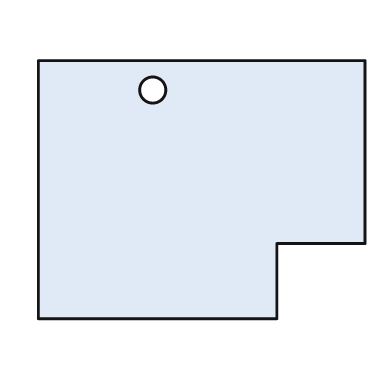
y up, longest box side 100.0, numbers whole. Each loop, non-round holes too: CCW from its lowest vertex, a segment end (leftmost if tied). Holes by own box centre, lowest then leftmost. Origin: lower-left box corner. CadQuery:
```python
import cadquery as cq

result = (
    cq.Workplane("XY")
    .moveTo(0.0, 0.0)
    .lineTo(73.0, 0.0)
    .lineTo(73.0, 23.0)
    .lineTo(100.0, 23.0)
    .lineTo(100.0, 79.0)
    .lineTo(0.0, 79.0)
    .close()
    .moveTo(35.0, 70.0)
    .circle(4.0)
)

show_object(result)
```